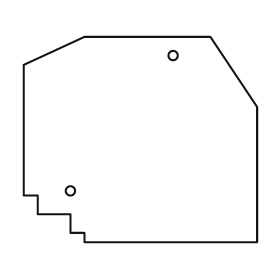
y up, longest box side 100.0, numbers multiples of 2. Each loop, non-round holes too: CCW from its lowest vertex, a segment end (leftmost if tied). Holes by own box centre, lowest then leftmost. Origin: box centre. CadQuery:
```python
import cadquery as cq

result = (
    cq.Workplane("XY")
    .moveTo(-24.0, -44.0)
    .lineTo(50.0, -44.0)
    .lineTo(50.0, 14.0)
    .lineTo(30.0, 44.0)
    .lineTo(-24.0, 44.0)
    .lineTo(-50.0, 32.0)
    .lineTo(-50.0, -24.0)
    .lineTo(-44.0, -24.0)
    .lineTo(-44.0, -32.0)
    .lineTo(-30.0, -32.0)
    .lineTo(-30.0, -40.0)
    .lineTo(-24.0, -40.0)
    .close()
    .moveTo(-30.0, -22.0)
    .circle(2.0)
    .moveTo(14.0, 36.0)
    .circle(2.0)
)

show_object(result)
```